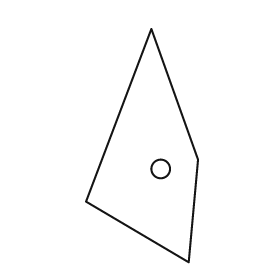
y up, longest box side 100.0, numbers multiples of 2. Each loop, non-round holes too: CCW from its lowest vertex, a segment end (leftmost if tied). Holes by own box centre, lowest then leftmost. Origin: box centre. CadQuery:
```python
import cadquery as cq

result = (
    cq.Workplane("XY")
    .moveTo(20.0, -50.0)
    .lineTo(24.0, -6.0)
    .lineTo(4.0, 50.0)
    .lineTo(-24.0, -24.0)
    .close()
    .moveTo(8.0, -10.0)
    .circle(4.0)
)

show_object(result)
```